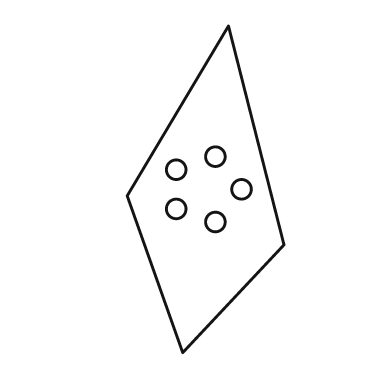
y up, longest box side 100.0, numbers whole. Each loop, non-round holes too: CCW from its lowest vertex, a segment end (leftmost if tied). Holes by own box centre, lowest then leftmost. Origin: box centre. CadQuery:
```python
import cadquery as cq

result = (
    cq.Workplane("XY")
    .moveTo(-7.0, -50.0)
    .lineTo(24.0, -17.0)
    .lineTo(7.0, 50.0)
    .lineTo(-24.0, -2.0)
    .close()
    .moveTo(3.0, -10.0)
    .circle(3.0)
    .moveTo(-9.0, -6.0)
    .circle(3.0)
    .moveTo(11.0, 0.0)
    .circle(3.0)
    .moveTo(-9.0, 6.0)
    .circle(3.0)
    .moveTo(3.0, 10.0)
    .circle(3.0)
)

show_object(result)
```